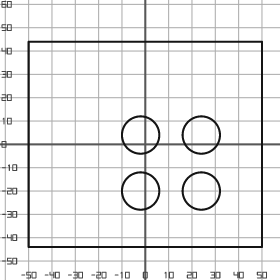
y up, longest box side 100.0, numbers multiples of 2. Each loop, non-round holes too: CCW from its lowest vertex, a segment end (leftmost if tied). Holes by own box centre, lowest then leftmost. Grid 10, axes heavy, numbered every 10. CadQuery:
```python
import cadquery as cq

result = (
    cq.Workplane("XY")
    .moveTo(-50.0, -44.0)
    .lineTo(50.0, -44.0)
    .lineTo(50.0, 44.0)
    .lineTo(-50.0, 44.0)
    .close()
    .moveTo(-2.0, -20.0)
    .circle(8.0)
    .moveTo(24.0, -20.0)
    .circle(8.0)
    .moveTo(-2.0, 4.0)
    .circle(8.0)
    .moveTo(24.0, 4.0)
    .circle(8.0)
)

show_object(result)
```